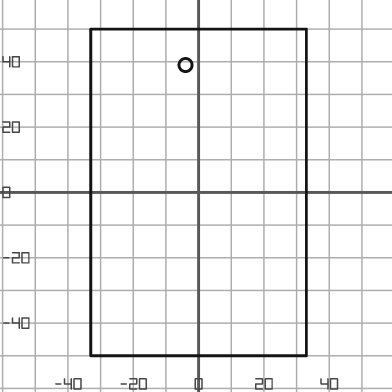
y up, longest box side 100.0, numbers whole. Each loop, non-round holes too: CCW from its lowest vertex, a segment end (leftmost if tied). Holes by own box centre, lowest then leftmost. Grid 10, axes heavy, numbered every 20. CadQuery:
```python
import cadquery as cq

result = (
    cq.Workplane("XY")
    .moveTo(-33.0, -50.0)
    .lineTo(33.0, -50.0)
    .lineTo(33.0, 50.0)
    .lineTo(-33.0, 50.0)
    .close()
    .moveTo(-4.0, 39.0)
    .circle(2.0)
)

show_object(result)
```